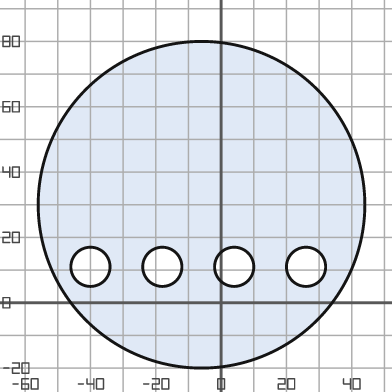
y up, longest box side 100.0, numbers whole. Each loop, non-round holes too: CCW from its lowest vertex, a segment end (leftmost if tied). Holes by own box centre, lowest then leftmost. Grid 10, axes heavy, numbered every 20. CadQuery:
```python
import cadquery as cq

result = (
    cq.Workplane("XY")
    .moveTo(-6.0, 30.0)
    .circle(50.0)
    .moveTo(-40.0, 11.0)
    .circle(6.0)
    .moveTo(-18.0, 11.0)
    .circle(6.0)
    .moveTo(4.0, 11.0)
    .circle(6.0)
    .moveTo(26.0, 11.0)
    .circle(6.0)
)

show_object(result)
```